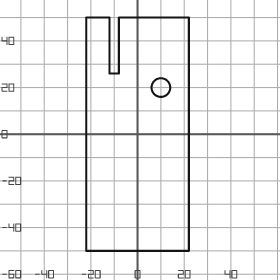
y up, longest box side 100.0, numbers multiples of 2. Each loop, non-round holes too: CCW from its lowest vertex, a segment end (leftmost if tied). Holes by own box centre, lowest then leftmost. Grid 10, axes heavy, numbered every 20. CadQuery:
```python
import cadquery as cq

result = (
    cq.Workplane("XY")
    .moveTo(-22.0, -50.0)
    .lineTo(22.0, -50.0)
    .lineTo(22.0, 50.0)
    .lineTo(-8.0, 50.0)
    .lineTo(-8.0, 26.0)
    .lineTo(-12.0, 26.0)
    .lineTo(-12.0, 50.0)
    .lineTo(-22.0, 50.0)
    .close()
    .moveTo(10.0, 20.0)
    .circle(4.0)
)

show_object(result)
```